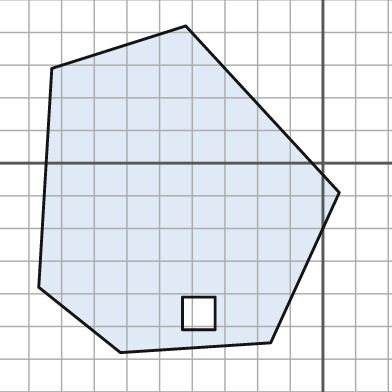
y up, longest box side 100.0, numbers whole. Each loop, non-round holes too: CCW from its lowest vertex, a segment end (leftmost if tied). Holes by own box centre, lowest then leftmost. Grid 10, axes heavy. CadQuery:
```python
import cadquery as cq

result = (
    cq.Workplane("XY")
    .moveTo(-62.0, -58.0)
    .lineTo(-16.0, -55.0)
    .lineTo(5.0, -9.0)
    .lineTo(-42.0, 42.0)
    .lineTo(-83.0, 29.0)
    .lineTo(-87.0, -38.0)
    .close()
    .moveTo(-43.0, -51.0)
    .lineTo(-33.0, -51.0)
    .lineTo(-33.0, -41.0)
    .lineTo(-43.0, -41.0)
    .close()
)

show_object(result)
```